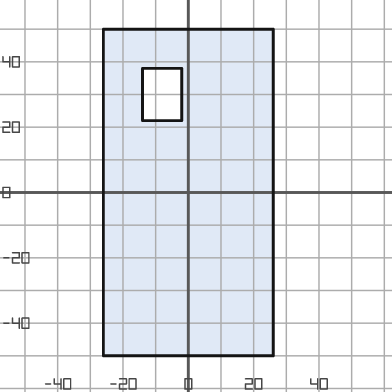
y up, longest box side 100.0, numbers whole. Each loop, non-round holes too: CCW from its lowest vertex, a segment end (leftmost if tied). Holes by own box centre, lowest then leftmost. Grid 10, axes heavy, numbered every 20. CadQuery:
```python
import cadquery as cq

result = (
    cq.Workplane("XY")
    .moveTo(-26.0, -50.0)
    .lineTo(26.0, -50.0)
    .lineTo(26.0, 50.0)
    .lineTo(-26.0, 50.0)
    .close()
    .moveTo(-14.0, 22.0)
    .lineTo(-2.0, 22.0)
    .lineTo(-2.0, 38.0)
    .lineTo(-14.0, 38.0)
    .close()
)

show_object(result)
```